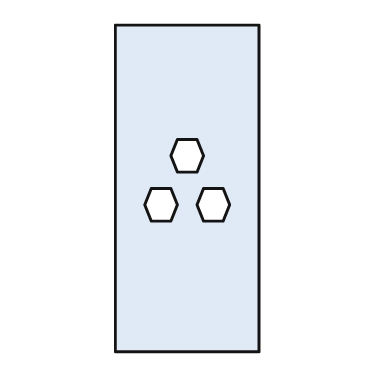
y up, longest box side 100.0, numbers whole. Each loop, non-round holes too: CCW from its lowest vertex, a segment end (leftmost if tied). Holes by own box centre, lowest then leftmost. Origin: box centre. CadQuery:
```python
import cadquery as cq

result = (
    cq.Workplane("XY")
    .moveTo(-22.0, -50.0)
    .lineTo(22.0, -50.0)
    .lineTo(22.0, 50.0)
    .lineTo(-22.0, 50.0)
    .close()
    .moveTo(-11.0, -10.0)
    .lineTo(-5.0, -10.0)
    .lineTo(-3.0, -5.0)
    .lineTo(-5.0, 0.0)
    .lineTo(-11.0, 0.0)
    .lineTo(-13.0, -5.0)
    .close()
    .moveTo(5.0, -10.0)
    .lineTo(11.0, -10.0)
    .lineTo(13.0, -5.0)
    .lineTo(11.0, 0.0)
    .lineTo(5.0, 0.0)
    .lineTo(3.0, -5.0)
    .close()
    .moveTo(-3.0, 5.0)
    .lineTo(3.0, 5.0)
    .lineTo(5.0, 10.0)
    .lineTo(3.0, 15.0)
    .lineTo(-3.0, 15.0)
    .lineTo(-5.0, 10.0)
    .close()
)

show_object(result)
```